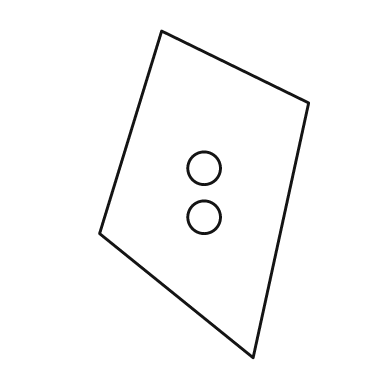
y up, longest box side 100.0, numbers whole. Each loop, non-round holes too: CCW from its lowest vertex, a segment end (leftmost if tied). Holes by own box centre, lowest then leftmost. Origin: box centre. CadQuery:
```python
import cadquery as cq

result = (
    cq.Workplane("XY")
    .moveTo(15.0, -50.0)
    .lineTo(32.0, 28.0)
    .lineTo(-13.0, 50.0)
    .lineTo(-32.0, -12.0)
    .close()
    .moveTo(0.0, -7.0)
    .circle(5.0)
    .moveTo(0.0, 8.0)
    .circle(5.0)
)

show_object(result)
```